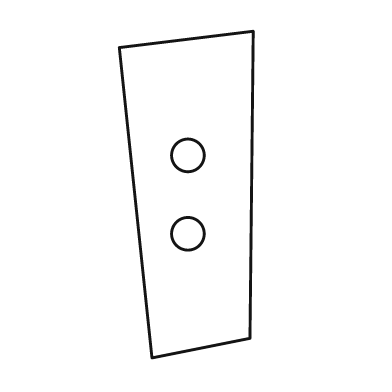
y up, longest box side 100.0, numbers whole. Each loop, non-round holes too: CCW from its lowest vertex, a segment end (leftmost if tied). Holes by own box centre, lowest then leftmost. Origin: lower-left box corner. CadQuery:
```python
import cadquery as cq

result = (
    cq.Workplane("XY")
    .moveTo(10.0, 0.0)
    .lineTo(40.0, 6.0)
    .lineTo(41.0, 100.0)
    .lineTo(0.0, 95.0)
    .close()
    .moveTo(21.0, 38.0)
    .circle(5.0)
    .moveTo(21.0, 62.0)
    .circle(5.0)
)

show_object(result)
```